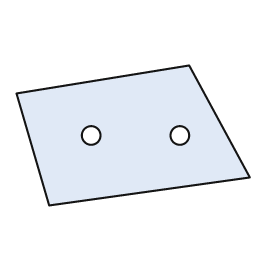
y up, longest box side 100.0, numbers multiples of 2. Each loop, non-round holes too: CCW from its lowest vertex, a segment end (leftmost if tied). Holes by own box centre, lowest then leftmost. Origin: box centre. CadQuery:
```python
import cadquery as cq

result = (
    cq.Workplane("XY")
    .moveTo(-36.0, -30.0)
    .lineTo(50.0, -18.0)
    .lineTo(24.0, 30.0)
    .lineTo(-50.0, 18.0)
    .close()
    .moveTo(-18.0, 0.0)
    .circle(4.0)
    .moveTo(20.0, 0.0)
    .circle(4.0)
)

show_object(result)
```